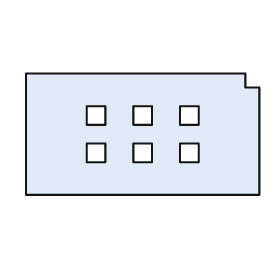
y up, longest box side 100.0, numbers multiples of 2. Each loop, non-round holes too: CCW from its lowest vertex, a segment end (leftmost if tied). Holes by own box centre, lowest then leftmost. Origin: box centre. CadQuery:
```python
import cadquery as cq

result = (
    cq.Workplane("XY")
    .moveTo(-50.0, -26.0)
    .lineTo(50.0, -26.0)
    .lineTo(50.0, 20.0)
    .lineTo(44.0, 20.0)
    .lineTo(44.0, 26.0)
    .lineTo(-50.0, 26.0)
    .close()
    .moveTo(-24.0, -12.0)
    .lineTo(-16.0, -12.0)
    .lineTo(-16.0, -4.0)
    .lineTo(-24.0, -4.0)
    .close()
    .moveTo(-4.0, -12.0)
    .lineTo(4.0, -12.0)
    .lineTo(4.0, -4.0)
    .lineTo(-4.0, -4.0)
    .close()
    .moveTo(16.0, -12.0)
    .lineTo(24.0, -12.0)
    .lineTo(24.0, -4.0)
    .lineTo(16.0, -4.0)
    .close()
    .moveTo(-24.0, 4.0)
    .lineTo(-16.0, 4.0)
    .lineTo(-16.0, 12.0)
    .lineTo(-24.0, 12.0)
    .close()
    .moveTo(-4.0, 4.0)
    .lineTo(4.0, 4.0)
    .lineTo(4.0, 12.0)
    .lineTo(-4.0, 12.0)
    .close()
    .moveTo(16.0, 4.0)
    .lineTo(24.0, 4.0)
    .lineTo(24.0, 12.0)
    .lineTo(16.0, 12.0)
    .close()
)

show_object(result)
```